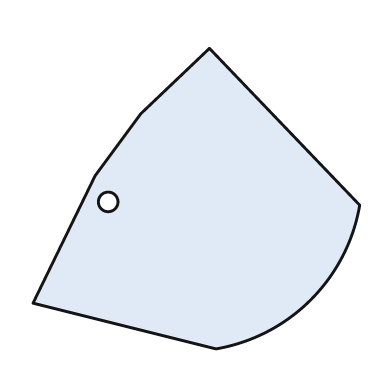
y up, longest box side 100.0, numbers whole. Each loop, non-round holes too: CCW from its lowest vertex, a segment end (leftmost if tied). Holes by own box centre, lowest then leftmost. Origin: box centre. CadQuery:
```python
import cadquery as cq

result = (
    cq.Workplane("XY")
    .moveTo(6.0, -46.0)
    .threePointArc((35.0, -31.0), (50.0, -2.0))
    .lineTo(4.0, 46.0)
    .lineTo(-17.0, 26.0)
    .lineTo(-31.0, 7.0)
    .lineTo(-50.0, -32.0)
    .close()
    .moveTo(-27.0, -1.0)
    .circle(3.0)
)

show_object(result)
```